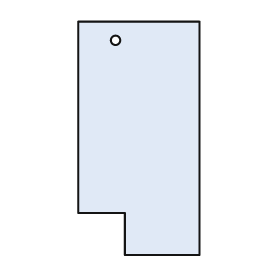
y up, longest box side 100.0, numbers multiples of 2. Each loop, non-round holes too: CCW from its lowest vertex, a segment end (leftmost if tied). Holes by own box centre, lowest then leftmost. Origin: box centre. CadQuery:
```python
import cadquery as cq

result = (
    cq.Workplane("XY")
    .moveTo(-6.0, -50.0)
    .lineTo(26.0, -50.0)
    .lineTo(26.0, 50.0)
    .lineTo(-26.0, 50.0)
    .lineTo(-26.0, -32.0)
    .lineTo(-6.0, -32.0)
    .close()
    .moveTo(-10.0, 42.0)
    .circle(2.0)
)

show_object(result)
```